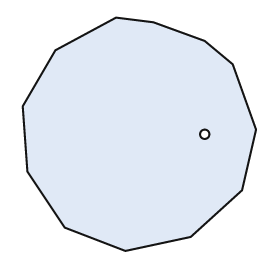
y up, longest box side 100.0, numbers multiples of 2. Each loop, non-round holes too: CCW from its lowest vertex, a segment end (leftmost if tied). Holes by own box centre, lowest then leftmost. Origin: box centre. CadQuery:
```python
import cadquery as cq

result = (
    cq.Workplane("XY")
    .moveTo(-6.0, -50.0)
    .lineTo(22.0, -44.0)
    .lineTo(44.0, -24.0)
    .lineTo(50.0, 2.0)
    .lineTo(40.0, 30.0)
    .lineTo(28.0, 40.0)
    .lineTo(6.0, 48.0)
    .lineTo(-10.0, 50.0)
    .lineTo(-36.0, 36.0)
    .lineTo(-50.0, 12.0)
    .lineTo(-48.0, -16.0)
    .lineTo(-32.0, -40.0)
    .close()
    .moveTo(28.0, 0.0)
    .circle(2.0)
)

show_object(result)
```